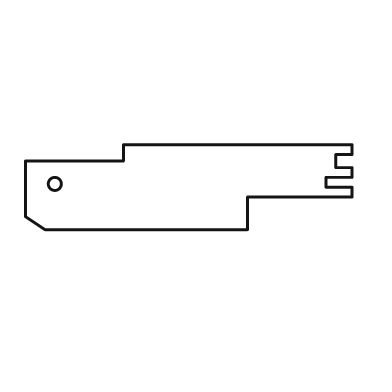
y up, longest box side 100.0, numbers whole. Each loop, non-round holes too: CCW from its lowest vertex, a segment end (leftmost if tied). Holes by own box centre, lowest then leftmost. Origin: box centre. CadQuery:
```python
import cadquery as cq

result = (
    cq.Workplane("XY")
    .moveTo(-44.0, -13.0)
    .lineTo(18.0, -13.0)
    .lineTo(18.0, -3.0)
    .lineTo(50.0, -3.0)
    .lineTo(50.0, 0.0)
    .lineTo(42.0, 0.0)
    .lineTo(42.0, 3.0)
    .lineTo(50.0, 3.0)
    .lineTo(50.0, 6.0)
    .lineTo(45.0, 6.0)
    .lineTo(45.0, 10.0)
    .lineTo(50.0, 10.0)
    .lineTo(50.0, 13.0)
    .lineTo(-20.0, 13.0)
    .lineTo(-20.0, 8.0)
    .lineTo(-50.0, 8.0)
    .lineTo(-50.0, -9.0)
    .close()
    .moveTo(-41.0, 1.0)
    .circle(2.0)
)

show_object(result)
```